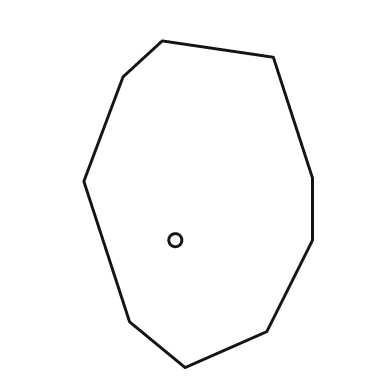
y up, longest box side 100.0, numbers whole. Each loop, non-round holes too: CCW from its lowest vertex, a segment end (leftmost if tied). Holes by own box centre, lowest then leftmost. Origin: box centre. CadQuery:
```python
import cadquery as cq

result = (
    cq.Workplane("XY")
    .moveTo(-4.0, -50.0)
    .lineTo(21.0, -39.0)
    .lineTo(35.0, -11.0)
    .lineTo(35.0, 8.0)
    .lineTo(23.0, 45.0)
    .lineTo(-11.0, 50.0)
    .lineTo(-23.0, 39.0)
    .lineTo(-35.0, 7.0)
    .lineTo(-21.0, -36.0)
    .close()
    .moveTo(-7.0, -11.0)
    .circle(2.0)
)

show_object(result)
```